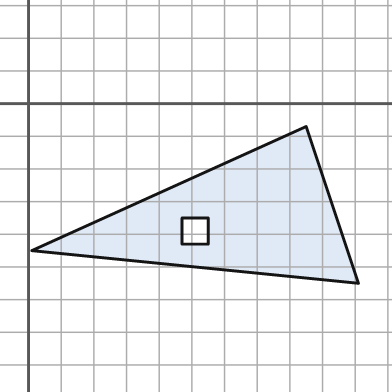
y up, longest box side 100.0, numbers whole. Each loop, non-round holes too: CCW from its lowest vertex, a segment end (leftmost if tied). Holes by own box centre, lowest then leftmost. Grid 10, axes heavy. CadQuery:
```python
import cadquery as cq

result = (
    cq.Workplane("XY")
    .moveTo(101.0, -55.0)
    .lineTo(85.0, -7.0)
    .lineTo(1.0, -45.0)
    .close()
    .moveTo(47.0, -43.0)
    .lineTo(55.0, -43.0)
    .lineTo(55.0, -35.0)
    .lineTo(47.0, -35.0)
    .close()
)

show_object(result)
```